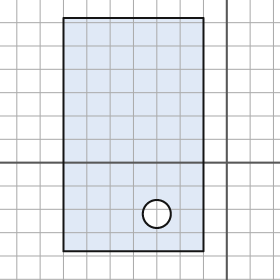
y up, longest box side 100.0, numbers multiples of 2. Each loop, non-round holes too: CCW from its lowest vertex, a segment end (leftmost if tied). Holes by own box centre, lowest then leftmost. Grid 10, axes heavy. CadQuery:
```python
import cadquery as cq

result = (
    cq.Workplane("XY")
    .moveTo(-70.0, -38.0)
    .lineTo(-10.0, -38.0)
    .lineTo(-10.0, 62.0)
    .lineTo(-70.0, 62.0)
    .close()
    .moveTo(-30.0, -22.0)
    .circle(6.0)
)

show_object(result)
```